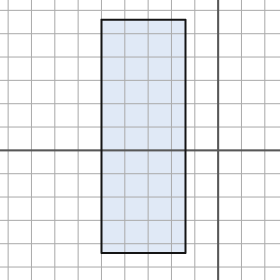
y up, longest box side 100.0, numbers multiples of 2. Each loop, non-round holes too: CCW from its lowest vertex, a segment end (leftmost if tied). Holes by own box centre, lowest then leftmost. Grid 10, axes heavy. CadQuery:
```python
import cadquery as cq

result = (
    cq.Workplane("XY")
    .moveTo(-50.0, -44.0)
    .lineTo(-14.0, -44.0)
    .lineTo(-14.0, 56.0)
    .lineTo(-50.0, 56.0)
    .close()
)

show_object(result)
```